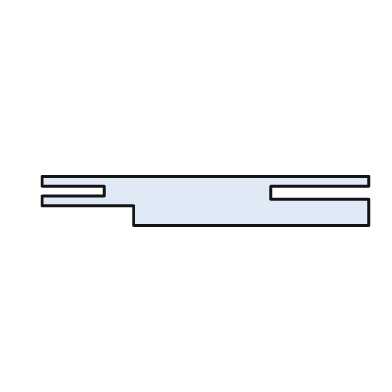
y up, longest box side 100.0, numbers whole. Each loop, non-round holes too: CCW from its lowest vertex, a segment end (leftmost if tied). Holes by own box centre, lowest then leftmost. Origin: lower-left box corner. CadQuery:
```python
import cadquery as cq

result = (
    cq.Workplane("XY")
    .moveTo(28.0, 0.0)
    .lineTo(100.0, 0.0)
    .lineTo(100.0, 8.0)
    .lineTo(70.0, 8.0)
    .lineTo(70.0, 12.0)
    .lineTo(100.0, 12.0)
    .lineTo(100.0, 15.0)
    .lineTo(0.0, 15.0)
    .lineTo(0.0, 12.0)
    .lineTo(19.0, 12.0)
    .lineTo(19.0, 9.0)
    .lineTo(0.0, 9.0)
    .lineTo(0.0, 6.0)
    .lineTo(28.0, 6.0)
    .close()
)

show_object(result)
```